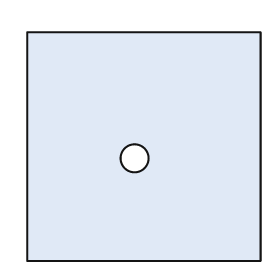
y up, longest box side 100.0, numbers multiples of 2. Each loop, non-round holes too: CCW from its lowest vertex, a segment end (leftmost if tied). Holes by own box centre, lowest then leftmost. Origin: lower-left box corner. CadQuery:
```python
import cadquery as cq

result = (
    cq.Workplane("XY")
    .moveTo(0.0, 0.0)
    .lineTo(100.0, 0.0)
    .lineTo(100.0, 98.0)
    .lineTo(0.0, 98.0)
    .close()
    .moveTo(46.0, 44.0)
    .circle(6.0)
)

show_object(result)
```